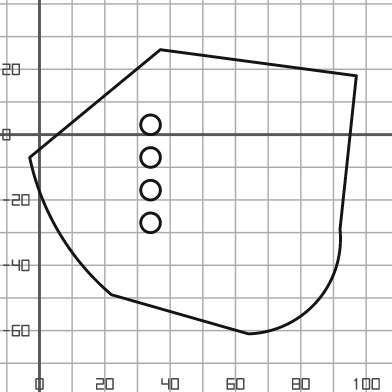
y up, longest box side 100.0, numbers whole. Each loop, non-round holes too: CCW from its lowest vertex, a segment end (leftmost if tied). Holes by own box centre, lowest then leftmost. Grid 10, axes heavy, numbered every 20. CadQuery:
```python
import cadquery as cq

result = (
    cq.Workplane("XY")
    .moveTo(64.0, -61.0)
    .threePointArc((85.0, -51.0), (92.0, -29.0))
    .lineTo(97.0, 18.0)
    .lineTo(37.0, 26.0)
    .lineTo(-3.0, -7.0)
    .threePointArc((6.0, -30.0), (22.0, -49.0))
    .close()
    .moveTo(34.0, -27.0)
    .circle(3.0)
    .moveTo(34.0, -17.0)
    .circle(3.0)
    .moveTo(34.0, -7.0)
    .circle(3.0)
    .moveTo(34.0, 3.0)
    .circle(3.0)
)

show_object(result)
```